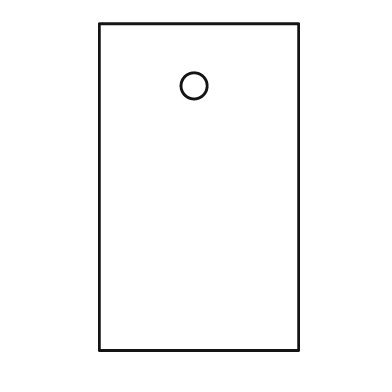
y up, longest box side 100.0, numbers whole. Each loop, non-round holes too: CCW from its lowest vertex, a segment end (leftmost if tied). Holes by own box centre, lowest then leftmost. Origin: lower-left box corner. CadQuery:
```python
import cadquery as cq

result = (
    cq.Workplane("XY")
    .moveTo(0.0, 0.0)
    .lineTo(61.0, 0.0)
    .lineTo(61.0, 100.0)
    .lineTo(0.0, 100.0)
    .close()
    .moveTo(29.0, 81.0)
    .circle(4.0)
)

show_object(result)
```